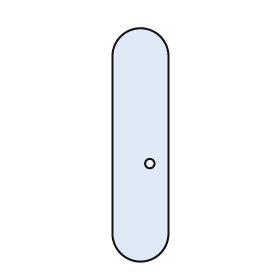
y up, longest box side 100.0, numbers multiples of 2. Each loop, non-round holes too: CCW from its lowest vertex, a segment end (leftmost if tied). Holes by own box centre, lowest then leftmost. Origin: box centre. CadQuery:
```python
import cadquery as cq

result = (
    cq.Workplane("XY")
    .moveTo(-12.0, -38.0)
    .threePointArc((0.0, -50.0), (12.0, -38.0))
    .lineTo(12.0, 38.0)
    .threePointArc((0.0, 50.0), (-12.0, 38.0))
    .close()
    .moveTo(4.0, -8.0)
    .circle(2.0)
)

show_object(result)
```